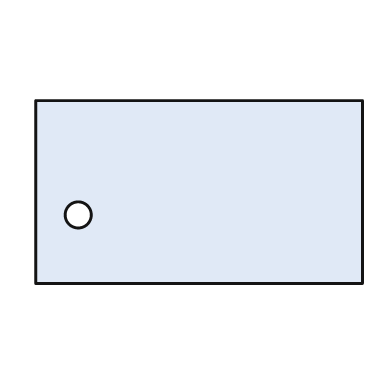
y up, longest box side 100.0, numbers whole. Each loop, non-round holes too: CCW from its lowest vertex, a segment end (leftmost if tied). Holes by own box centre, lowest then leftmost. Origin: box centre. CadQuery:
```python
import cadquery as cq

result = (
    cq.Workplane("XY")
    .moveTo(-50.0, -28.0)
    .lineTo(50.0, -28.0)
    .lineTo(50.0, 28.0)
    .lineTo(-50.0, 28.0)
    .close()
    .moveTo(-37.0, -7.0)
    .circle(4.0)
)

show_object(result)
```